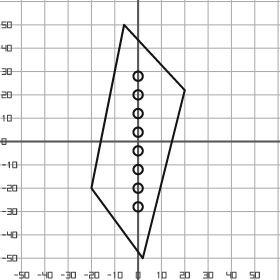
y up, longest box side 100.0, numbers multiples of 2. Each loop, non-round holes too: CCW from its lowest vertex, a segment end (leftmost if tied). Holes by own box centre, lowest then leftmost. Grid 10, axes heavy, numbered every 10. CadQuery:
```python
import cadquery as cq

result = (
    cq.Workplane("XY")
    .moveTo(2.0, -50.0)
    .lineTo(20.0, 22.0)
    .lineTo(-6.0, 50.0)
    .lineTo(-20.0, -20.0)
    .close()
    .moveTo(0.0, -28.0)
    .circle(2.0)
    .moveTo(0.0, -20.0)
    .circle(2.0)
    .moveTo(0.0, -12.0)
    .circle(2.0)
    .moveTo(0.0, -4.0)
    .circle(2.0)
    .moveTo(0.0, 4.0)
    .circle(2.0)
    .moveTo(0.0, 12.0)
    .circle(2.0)
    .moveTo(0.0, 20.0)
    .circle(2.0)
    .moveTo(0.0, 28.0)
    .circle(2.0)
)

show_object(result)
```